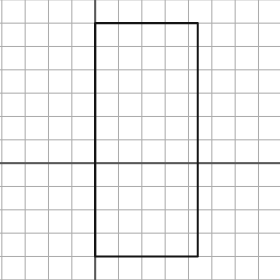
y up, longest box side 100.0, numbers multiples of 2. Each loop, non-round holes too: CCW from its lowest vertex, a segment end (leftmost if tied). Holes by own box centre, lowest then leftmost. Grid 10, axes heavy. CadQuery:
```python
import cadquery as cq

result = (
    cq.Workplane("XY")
    .moveTo(0.0, -40.0)
    .lineTo(44.0, -40.0)
    .lineTo(44.0, 60.0)
    .lineTo(0.0, 60.0)
    .close()
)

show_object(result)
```